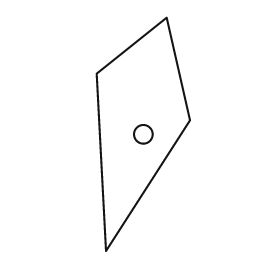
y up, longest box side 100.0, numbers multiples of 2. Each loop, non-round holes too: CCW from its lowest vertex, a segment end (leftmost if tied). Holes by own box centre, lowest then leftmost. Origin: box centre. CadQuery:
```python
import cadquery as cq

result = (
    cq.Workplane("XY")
    .moveTo(-16.0, -50.0)
    .lineTo(20.0, 6.0)
    .lineTo(10.0, 50.0)
    .lineTo(-20.0, 26.0)
    .close()
    .moveTo(0.0, 0.0)
    .circle(4.0)
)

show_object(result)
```